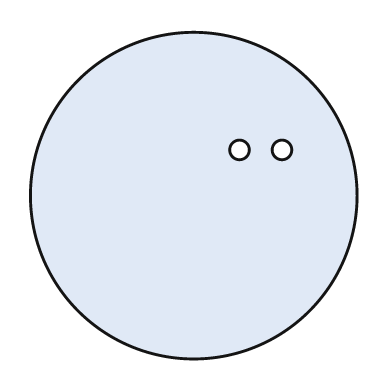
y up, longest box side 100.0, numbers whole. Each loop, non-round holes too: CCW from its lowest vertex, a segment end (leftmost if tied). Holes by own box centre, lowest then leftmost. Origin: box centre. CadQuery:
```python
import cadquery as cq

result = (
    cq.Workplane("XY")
    .moveTo(0.0, 0.0)
    .circle(50.0)
    .moveTo(14.0, 14.0)
    .circle(3.0)
    .moveTo(27.0, 14.0)
    .circle(3.0)
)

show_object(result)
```